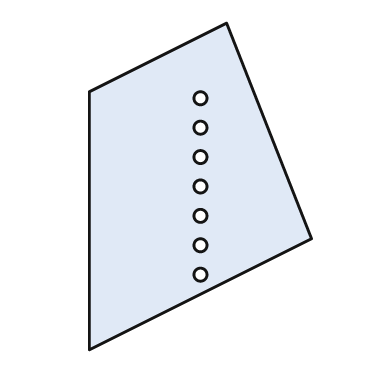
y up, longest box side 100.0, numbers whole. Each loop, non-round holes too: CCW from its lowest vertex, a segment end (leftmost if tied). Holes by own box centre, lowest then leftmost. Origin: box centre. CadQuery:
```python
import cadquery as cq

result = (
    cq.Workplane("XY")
    .moveTo(-34.0, -50.0)
    .lineTo(34.0, -16.0)
    .lineTo(8.0, 50.0)
    .lineTo(-34.0, 29.0)
    .close()
    .moveTo(0.0, -27.0)
    .circle(2.0)
    .moveTo(0.0, -18.0)
    .circle(2.0)
    .moveTo(0.0, -9.0)
    .circle(2.0)
    .moveTo(0.0, 0.0)
    .circle(2.0)
    .moveTo(0.0, 9.0)
    .circle(2.0)
    .moveTo(0.0, 18.0)
    .circle(2.0)
    .moveTo(0.0, 27.0)
    .circle(2.0)
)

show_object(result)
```